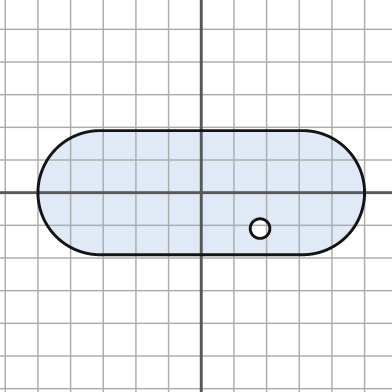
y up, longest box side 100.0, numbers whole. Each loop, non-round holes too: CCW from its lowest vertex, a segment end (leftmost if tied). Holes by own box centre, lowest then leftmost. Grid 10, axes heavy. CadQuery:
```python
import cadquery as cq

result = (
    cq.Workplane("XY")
    .moveTo(-31.0, -19.0)
    .lineTo(31.0, -19.0)
    .threePointArc((50.0, 0.0), (31.0, 19.0))
    .lineTo(-31.0, 19.0)
    .threePointArc((-50.0, 0.0), (-31.0, -19.0))
    .close()
    .moveTo(18.0, -11.0)
    .circle(3.0)
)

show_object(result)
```